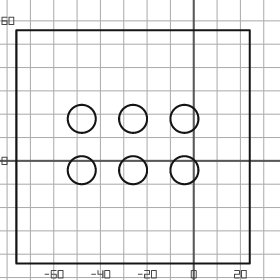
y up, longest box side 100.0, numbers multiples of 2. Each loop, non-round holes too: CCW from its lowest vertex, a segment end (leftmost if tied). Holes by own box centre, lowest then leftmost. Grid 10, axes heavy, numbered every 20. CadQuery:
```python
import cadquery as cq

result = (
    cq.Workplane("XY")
    .moveTo(-76.0, -44.0)
    .lineTo(24.0, -44.0)
    .lineTo(24.0, 56.0)
    .lineTo(-76.0, 56.0)
    .close()
    .moveTo(-48.0, -4.0)
    .circle(6.0)
    .moveTo(-26.0, -4.0)
    .circle(6.0)
    .moveTo(-4.0, -4.0)
    .circle(6.0)
    .moveTo(-48.0, 18.0)
    .circle(6.0)
    .moveTo(-26.0, 18.0)
    .circle(6.0)
    .moveTo(-4.0, 18.0)
    .circle(6.0)
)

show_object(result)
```